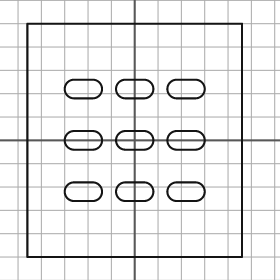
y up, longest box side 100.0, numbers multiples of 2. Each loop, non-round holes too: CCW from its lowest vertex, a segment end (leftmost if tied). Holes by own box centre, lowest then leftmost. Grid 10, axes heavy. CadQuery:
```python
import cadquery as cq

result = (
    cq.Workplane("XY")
    .moveTo(-46.0, -50.0)
    .lineTo(46.0, -50.0)
    .lineTo(46.0, 50.0)
    .lineTo(-46.0, 50.0)
    .close()
    .moveTo(-26.0, -26.0)
    .lineTo(-18.0, -26.0)
    .threePointArc((-14.0, -22.0), (-18.0, -18.0))
    .lineTo(-26.0, -18.0)
    .threePointArc((-30.0, -22.0), (-26.0, -26.0))
    .close()
    .moveTo(-4.0, -26.0)
    .lineTo(4.0, -26.0)
    .threePointArc((8.0, -22.0), (4.0, -18.0))
    .lineTo(-4.0, -18.0)
    .threePointArc((-8.0, -22.0), (-4.0, -26.0))
    .close()
    .moveTo(18.0, -26.0)
    .lineTo(26.0, -26.0)
    .threePointArc((30.0, -22.0), (26.0, -18.0))
    .lineTo(18.0, -18.0)
    .threePointArc((14.0, -22.0), (18.0, -26.0))
    .close()
    .moveTo(-26.0, -4.0)
    .lineTo(-18.0, -4.0)
    .threePointArc((-14.0, 0.0), (-18.0, 4.0))
    .lineTo(-26.0, 4.0)
    .threePointArc((-30.0, 0.0), (-26.0, -4.0))
    .close()
    .moveTo(-4.0, -4.0)
    .lineTo(4.0, -4.0)
    .threePointArc((8.0, 0.0), (4.0, 4.0))
    .lineTo(-4.0, 4.0)
    .threePointArc((-8.0, 0.0), (-4.0, -4.0))
    .close()
    .moveTo(18.0, -4.0)
    .lineTo(26.0, -4.0)
    .threePointArc((30.0, 0.0), (26.0, 4.0))
    .lineTo(18.0, 4.0)
    .threePointArc((14.0, 0.0), (18.0, -4.0))
    .close()
    .moveTo(-26.0, 18.0)
    .lineTo(-18.0, 18.0)
    .threePointArc((-14.0, 22.0), (-18.0, 26.0))
    .lineTo(-26.0, 26.0)
    .threePointArc((-30.0, 22.0), (-26.0, 18.0))
    .close()
    .moveTo(-4.0, 18.0)
    .lineTo(4.0, 18.0)
    .threePointArc((8.0, 22.0), (4.0, 26.0))
    .lineTo(-4.0, 26.0)
    .threePointArc((-8.0, 22.0), (-4.0, 18.0))
    .close()
    .moveTo(18.0, 18.0)
    .lineTo(26.0, 18.0)
    .threePointArc((30.0, 22.0), (26.0, 26.0))
    .lineTo(18.0, 26.0)
    .threePointArc((14.0, 22.0), (18.0, 18.0))
    .close()
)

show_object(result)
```